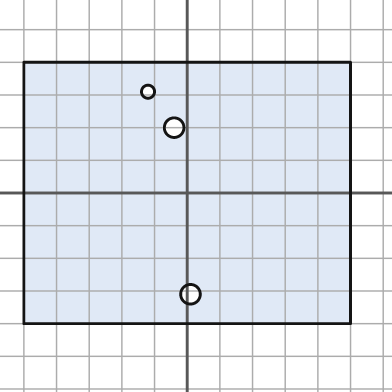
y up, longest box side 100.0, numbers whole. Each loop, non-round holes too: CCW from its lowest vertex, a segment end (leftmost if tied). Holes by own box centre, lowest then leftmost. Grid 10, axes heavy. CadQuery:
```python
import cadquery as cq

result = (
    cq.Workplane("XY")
    .moveTo(-50.0, -40.0)
    .lineTo(50.0, -40.0)
    .lineTo(50.0, 40.0)
    .lineTo(-50.0, 40.0)
    .close()
    .moveTo(1.0, -31.0)
    .circle(3.0)
    .moveTo(-4.0, 20.0)
    .circle(3.0)
    .moveTo(-12.0, 31.0)
    .circle(2.0)
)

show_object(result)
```